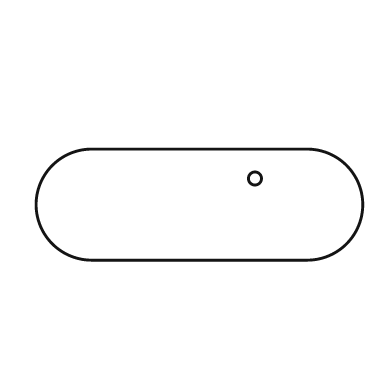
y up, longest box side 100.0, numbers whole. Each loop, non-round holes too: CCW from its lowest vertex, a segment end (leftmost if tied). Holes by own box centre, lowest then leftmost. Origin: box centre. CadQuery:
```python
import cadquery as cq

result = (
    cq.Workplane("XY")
    .moveTo(-33.0, -17.0)
    .lineTo(33.0, -17.0)
    .threePointArc((50.0, 0.0), (33.0, 17.0))
    .lineTo(-33.0, 17.0)
    .threePointArc((-50.0, 0.0), (-33.0, -17.0))
    .close()
    .moveTo(17.0, 8.0)
    .circle(2.0)
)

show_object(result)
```